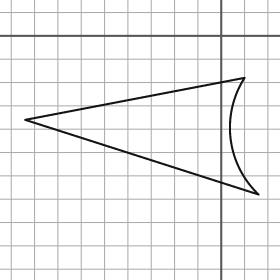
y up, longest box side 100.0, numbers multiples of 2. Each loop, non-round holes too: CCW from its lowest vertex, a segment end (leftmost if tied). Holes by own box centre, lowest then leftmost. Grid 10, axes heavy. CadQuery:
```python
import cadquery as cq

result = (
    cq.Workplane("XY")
    .moveTo(16.0, -68.0)
    .threePointArc((4.0, -44.0), (10.0, -18.0))
    .lineTo(-84.0, -36.0)
    .close()
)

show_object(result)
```